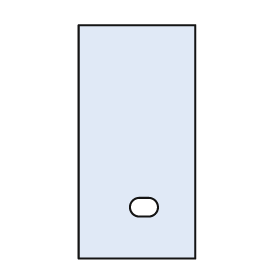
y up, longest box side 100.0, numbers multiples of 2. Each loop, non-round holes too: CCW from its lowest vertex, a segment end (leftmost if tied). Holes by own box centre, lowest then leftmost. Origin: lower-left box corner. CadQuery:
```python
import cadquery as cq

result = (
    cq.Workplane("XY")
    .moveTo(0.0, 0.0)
    .lineTo(50.0, 0.0)
    .lineTo(50.0, 100.0)
    .lineTo(0.0, 100.0)
    .close()
    .moveTo(26.0, 18.0)
    .lineTo(30.0, 18.0)
    .threePointArc((34.0, 22.0), (30.0, 26.0))
    .lineTo(26.0, 26.0)
    .threePointArc((22.0, 22.0), (26.0, 18.0))
    .close()
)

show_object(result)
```